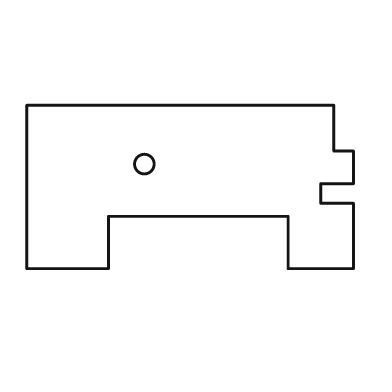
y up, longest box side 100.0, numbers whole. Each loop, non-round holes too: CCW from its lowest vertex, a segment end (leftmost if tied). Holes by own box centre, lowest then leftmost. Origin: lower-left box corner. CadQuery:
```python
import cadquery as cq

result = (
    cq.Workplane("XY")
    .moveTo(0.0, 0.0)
    .lineTo(25.0, 0.0)
    .lineTo(25.0, 16.0)
    .lineTo(80.0, 16.0)
    .lineTo(80.0, 0.0)
    .lineTo(100.0, 0.0)
    .lineTo(100.0, 20.0)
    .lineTo(90.0, 20.0)
    .lineTo(90.0, 26.0)
    .lineTo(100.0, 26.0)
    .lineTo(100.0, 36.0)
    .lineTo(94.0, 36.0)
    .lineTo(94.0, 50.0)
    .lineTo(0.0, 50.0)
    .close()
    .moveTo(36.0, 32.0)
    .circle(3.0)
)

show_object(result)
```